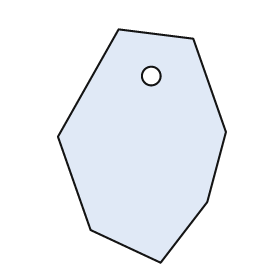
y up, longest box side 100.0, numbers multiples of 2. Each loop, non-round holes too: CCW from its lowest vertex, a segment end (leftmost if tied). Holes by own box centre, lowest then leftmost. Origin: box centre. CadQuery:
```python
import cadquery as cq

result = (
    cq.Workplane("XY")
    .moveTo(8.0, -50.0)
    .lineTo(28.0, -24.0)
    .lineTo(36.0, 6.0)
    .lineTo(22.0, 46.0)
    .lineTo(-10.0, 50.0)
    .lineTo(-36.0, 4.0)
    .lineTo(-22.0, -36.0)
    .close()
    .moveTo(4.0, 30.0)
    .circle(4.0)
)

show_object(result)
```